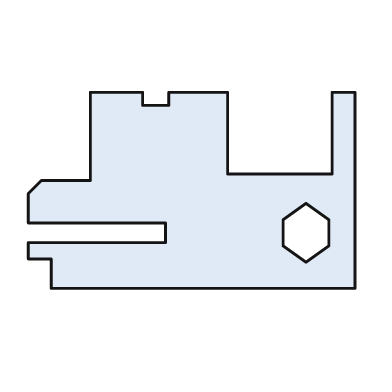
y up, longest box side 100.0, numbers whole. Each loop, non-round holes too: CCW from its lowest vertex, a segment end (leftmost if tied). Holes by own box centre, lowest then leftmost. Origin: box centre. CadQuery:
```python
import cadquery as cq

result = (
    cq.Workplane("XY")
    .moveTo(-43.0, -30.0)
    .lineTo(50.0, -30.0)
    .lineTo(50.0, 30.0)
    .lineTo(43.0, 30.0)
    .lineTo(43.0, 5.0)
    .lineTo(11.0, 5.0)
    .lineTo(11.0, 30.0)
    .lineTo(-7.0, 30.0)
    .lineTo(-7.0, 26.0)
    .lineTo(-15.0, 26.0)
    .lineTo(-15.0, 30.0)
    .lineTo(-31.0, 30.0)
    .lineTo(-31.0, 3.0)
    .lineTo(-46.0, 3.0)
    .lineTo(-50.0, -1.0)
    .lineTo(-50.0, -10.0)
    .lineTo(-8.0, -10.0)
    .lineTo(-8.0, -16.0)
    .lineTo(-50.0, -16.0)
    .lineTo(-50.0, -21.0)
    .lineTo(-43.0, -21.0)
    .close()
    .moveTo(35.0, -22.0)
    .lineTo(42.0, -17.0)
    .lineTo(42.0, -9.0)
    .lineTo(35.0, -4.0)
    .lineTo(28.0, -9.0)
    .lineTo(28.0, -17.0)
    .close()
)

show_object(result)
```